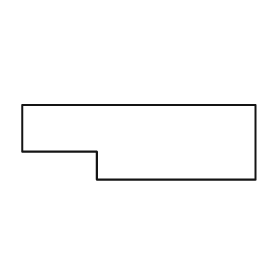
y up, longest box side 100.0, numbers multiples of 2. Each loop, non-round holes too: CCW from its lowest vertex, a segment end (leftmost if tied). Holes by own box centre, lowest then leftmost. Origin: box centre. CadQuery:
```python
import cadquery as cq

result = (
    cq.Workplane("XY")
    .moveTo(-18.0, -16.0)
    .lineTo(50.0, -16.0)
    .lineTo(50.0, 16.0)
    .lineTo(-50.0, 16.0)
    .lineTo(-50.0, -4.0)
    .lineTo(-18.0, -4.0)
    .close()
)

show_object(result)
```